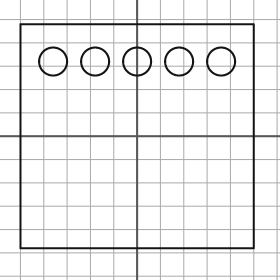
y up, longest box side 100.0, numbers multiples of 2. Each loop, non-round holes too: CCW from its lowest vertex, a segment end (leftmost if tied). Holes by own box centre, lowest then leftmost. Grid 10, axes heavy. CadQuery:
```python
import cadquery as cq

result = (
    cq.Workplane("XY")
    .moveTo(-50.0, -48.0)
    .lineTo(50.0, -48.0)
    .lineTo(50.0, 48.0)
    .lineTo(-50.0, 48.0)
    .close()
    .moveTo(-36.0, 32.0)
    .circle(6.0)
    .moveTo(-18.0, 32.0)
    .circle(6.0)
    .moveTo(0.0, 32.0)
    .circle(6.0)
    .moveTo(18.0, 32.0)
    .circle(6.0)
    .moveTo(36.0, 32.0)
    .circle(6.0)
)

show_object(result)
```